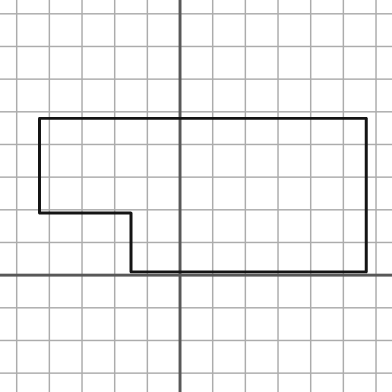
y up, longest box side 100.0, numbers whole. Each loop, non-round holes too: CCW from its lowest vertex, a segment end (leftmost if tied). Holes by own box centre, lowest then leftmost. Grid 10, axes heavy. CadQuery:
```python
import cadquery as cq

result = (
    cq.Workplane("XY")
    .moveTo(-15.0, 1.0)
    .lineTo(57.0, 1.0)
    .lineTo(57.0, 48.0)
    .lineTo(-43.0, 48.0)
    .lineTo(-43.0, 19.0)
    .lineTo(-15.0, 19.0)
    .close()
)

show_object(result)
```